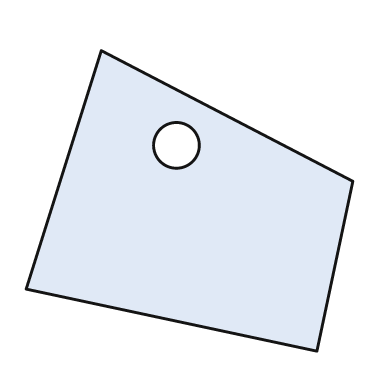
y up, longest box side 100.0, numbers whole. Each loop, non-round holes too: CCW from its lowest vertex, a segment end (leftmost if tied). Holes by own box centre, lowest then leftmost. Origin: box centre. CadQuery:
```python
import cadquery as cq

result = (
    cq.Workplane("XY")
    .moveTo(39.0, -46.0)
    .lineTo(50.0, 6.0)
    .lineTo(-27.0, 46.0)
    .lineTo(-50.0, -27.0)
    .close()
    .moveTo(-4.0, 17.0)
    .circle(7.0)
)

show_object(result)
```